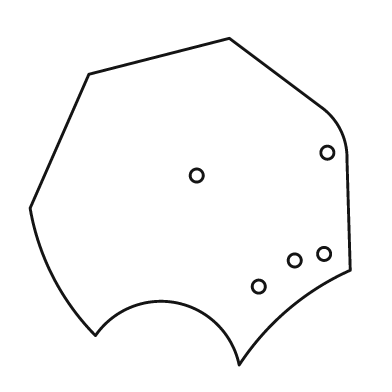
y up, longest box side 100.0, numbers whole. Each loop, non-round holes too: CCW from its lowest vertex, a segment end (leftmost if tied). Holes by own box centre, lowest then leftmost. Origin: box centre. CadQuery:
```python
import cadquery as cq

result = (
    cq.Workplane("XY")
    .moveTo(15.0, -50.0)
    .threePointArc((30.0, -33.0), (49.0, -21.0))
    .lineTo(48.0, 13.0)
    .threePointArc((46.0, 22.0), (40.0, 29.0))
    .lineTo(12.0, 50.0)
    .lineTo(-31.0, 39.0)
    .lineTo(-49.0, -2.0)
    .threePointArc((-42.0, -23.0), (-29.0, -41.0))
    .threePointArc((-4.0, -31.0), (15.0, -50.0))
    .close()
    .moveTo(21.0, -26.0)
    .circle(2.0)
    .moveTo(32.0, -18.0)
    .circle(2.0)
    .moveTo(41.0, -16.0)
    .circle(2.0)
    .moveTo(2.0, 8.0)
    .circle(2.0)
    .moveTo(42.0, 15.0)
    .circle(2.0)
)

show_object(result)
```